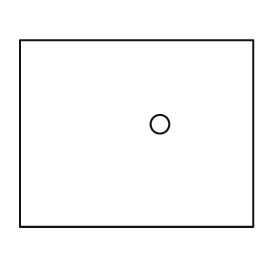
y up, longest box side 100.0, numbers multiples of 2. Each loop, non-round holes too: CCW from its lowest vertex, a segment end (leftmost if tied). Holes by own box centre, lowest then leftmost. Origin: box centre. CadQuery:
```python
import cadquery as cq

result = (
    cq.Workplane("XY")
    .moveTo(-50.0, -40.0)
    .lineTo(50.0, -40.0)
    .lineTo(50.0, 40.0)
    .lineTo(-50.0, 40.0)
    .close()
    .moveTo(10.0, 4.0)
    .circle(4.0)
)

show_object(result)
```